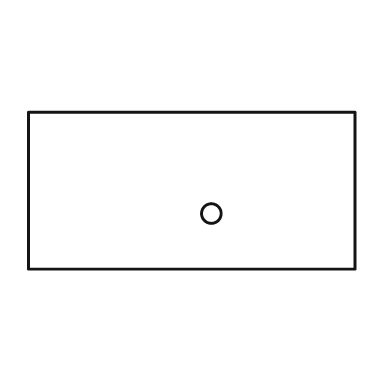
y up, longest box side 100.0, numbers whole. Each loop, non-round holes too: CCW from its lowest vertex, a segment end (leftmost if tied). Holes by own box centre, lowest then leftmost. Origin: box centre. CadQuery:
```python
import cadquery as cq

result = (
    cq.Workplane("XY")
    .moveTo(-50.0, -24.0)
    .lineTo(50.0, -24.0)
    .lineTo(50.0, 24.0)
    .lineTo(-50.0, 24.0)
    .close()
    .moveTo(6.0, -7.0)
    .circle(3.0)
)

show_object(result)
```